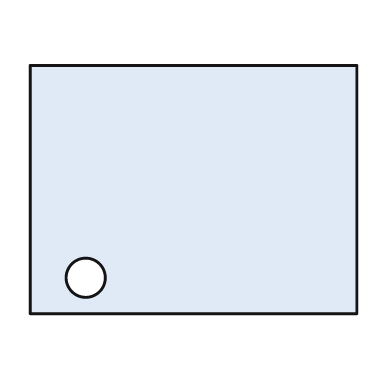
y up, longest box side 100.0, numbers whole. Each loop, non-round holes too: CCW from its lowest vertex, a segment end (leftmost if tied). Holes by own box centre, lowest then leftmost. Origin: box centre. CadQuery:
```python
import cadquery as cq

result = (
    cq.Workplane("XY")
    .moveTo(-50.0, -38.0)
    .lineTo(50.0, -38.0)
    .lineTo(50.0, 38.0)
    .lineTo(-50.0, 38.0)
    .close()
    .moveTo(-33.0, -27.0)
    .circle(6.0)
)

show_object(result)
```